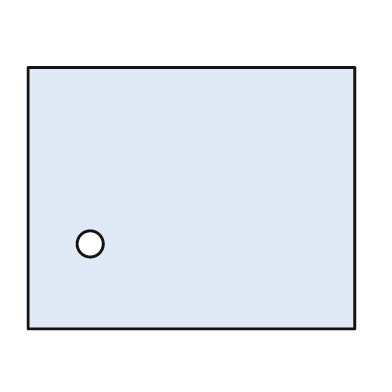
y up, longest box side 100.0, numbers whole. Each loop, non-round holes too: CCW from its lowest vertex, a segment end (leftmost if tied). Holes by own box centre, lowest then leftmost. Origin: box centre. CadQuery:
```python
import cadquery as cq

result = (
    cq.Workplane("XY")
    .moveTo(-50.0, -40.0)
    .lineTo(50.0, -40.0)
    .lineTo(50.0, 40.0)
    .lineTo(-50.0, 40.0)
    .close()
    .moveTo(-31.0, -14.0)
    .circle(4.0)
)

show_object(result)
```